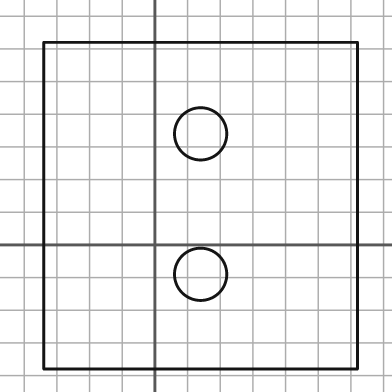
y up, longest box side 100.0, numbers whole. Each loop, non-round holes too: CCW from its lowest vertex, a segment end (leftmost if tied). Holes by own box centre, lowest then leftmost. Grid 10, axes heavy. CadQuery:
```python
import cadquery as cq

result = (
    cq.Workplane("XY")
    .moveTo(-34.0, -38.0)
    .lineTo(62.0, -38.0)
    .lineTo(62.0, 62.0)
    .lineTo(-34.0, 62.0)
    .close()
    .moveTo(14.0, -9.0)
    .circle(8.0)
    .moveTo(14.0, 34.0)
    .circle(8.0)
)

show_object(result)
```